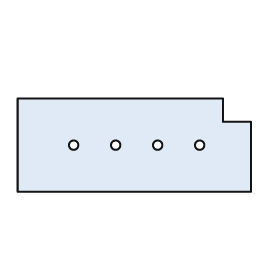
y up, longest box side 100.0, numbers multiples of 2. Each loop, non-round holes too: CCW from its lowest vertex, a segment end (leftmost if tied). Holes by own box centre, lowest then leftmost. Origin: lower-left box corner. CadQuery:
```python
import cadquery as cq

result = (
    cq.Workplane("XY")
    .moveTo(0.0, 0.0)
    .lineTo(100.0, 0.0)
    .lineTo(100.0, 30.0)
    .lineTo(88.0, 30.0)
    .lineTo(88.0, 40.0)
    .lineTo(0.0, 40.0)
    .close()
    .moveTo(24.0, 20.0)
    .circle(2.0)
    .moveTo(42.0, 20.0)
    .circle(2.0)
    .moveTo(60.0, 20.0)
    .circle(2.0)
    .moveTo(78.0, 20.0)
    .circle(2.0)
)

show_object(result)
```